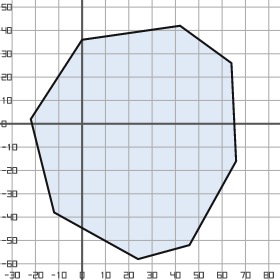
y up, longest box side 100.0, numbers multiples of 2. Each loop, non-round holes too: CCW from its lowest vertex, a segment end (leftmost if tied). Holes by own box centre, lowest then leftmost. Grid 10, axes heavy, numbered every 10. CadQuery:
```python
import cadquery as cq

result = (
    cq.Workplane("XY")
    .moveTo(24.0, -58.0)
    .lineTo(46.0, -52.0)
    .lineTo(66.0, -16.0)
    .lineTo(64.0, 26.0)
    .lineTo(42.0, 42.0)
    .lineTo(0.0, 36.0)
    .lineTo(-22.0, 2.0)
    .lineTo(-12.0, -38.0)
    .close()
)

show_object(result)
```